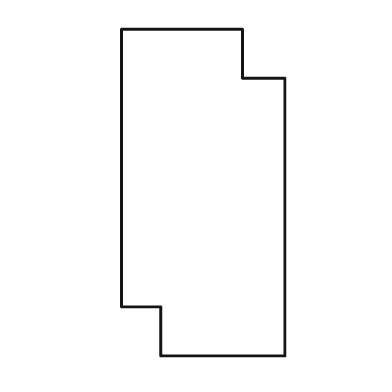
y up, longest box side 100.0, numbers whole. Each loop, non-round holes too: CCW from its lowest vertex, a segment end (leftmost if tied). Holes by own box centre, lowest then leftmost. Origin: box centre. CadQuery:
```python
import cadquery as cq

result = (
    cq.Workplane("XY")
    .moveTo(-13.0, -50.0)
    .lineTo(25.0, -50.0)
    .lineTo(25.0, 35.0)
    .lineTo(12.0, 35.0)
    .lineTo(12.0, 50.0)
    .lineTo(-25.0, 50.0)
    .lineTo(-25.0, -35.0)
    .lineTo(-13.0, -35.0)
    .close()
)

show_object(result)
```